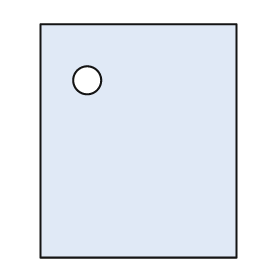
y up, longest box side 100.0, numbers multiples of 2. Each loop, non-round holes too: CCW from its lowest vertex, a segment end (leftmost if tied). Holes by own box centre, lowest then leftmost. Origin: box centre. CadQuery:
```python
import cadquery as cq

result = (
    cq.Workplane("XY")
    .moveTo(-42.0, -50.0)
    .lineTo(42.0, -50.0)
    .lineTo(42.0, 50.0)
    .lineTo(-42.0, 50.0)
    .close()
    .moveTo(-22.0, 26.0)
    .circle(6.0)
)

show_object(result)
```